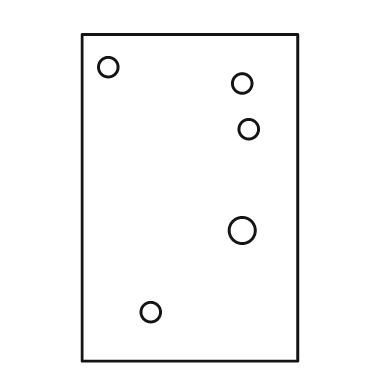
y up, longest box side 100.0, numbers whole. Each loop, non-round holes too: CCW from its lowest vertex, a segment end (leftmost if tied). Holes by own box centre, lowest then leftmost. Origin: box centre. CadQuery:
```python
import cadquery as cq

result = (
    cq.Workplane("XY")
    .moveTo(-33.0, -50.0)
    .lineTo(33.0, -50.0)
    .lineTo(33.0, 50.0)
    .lineTo(-33.0, 50.0)
    .close()
    .moveTo(-12.0, -35.0)
    .circle(3.0)
    .moveTo(16.0, -10.0)
    .circle(4.0)
    .moveTo(18.0, 21.0)
    .circle(3.0)
    .moveTo(16.0, 35.0)
    .circle(3.0)
    .moveTo(-25.0, 40.0)
    .circle(3.0)
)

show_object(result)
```